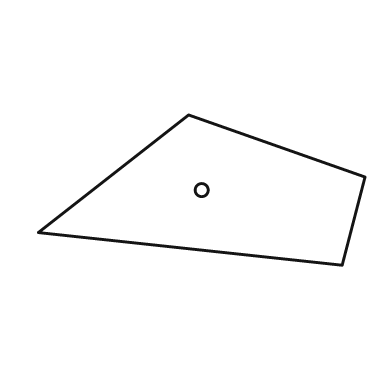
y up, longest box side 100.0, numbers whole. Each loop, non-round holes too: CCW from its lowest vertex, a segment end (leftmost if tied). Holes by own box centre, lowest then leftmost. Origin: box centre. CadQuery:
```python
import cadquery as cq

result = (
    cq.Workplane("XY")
    .moveTo(43.0, -23.0)
    .lineTo(50.0, 4.0)
    .lineTo(-4.0, 23.0)
    .lineTo(-50.0, -13.0)
    .close()
    .moveTo(0.0, 0.0)
    .circle(2.0)
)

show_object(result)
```